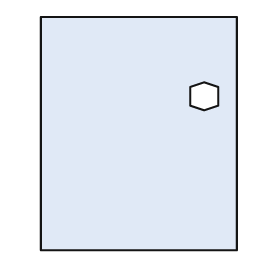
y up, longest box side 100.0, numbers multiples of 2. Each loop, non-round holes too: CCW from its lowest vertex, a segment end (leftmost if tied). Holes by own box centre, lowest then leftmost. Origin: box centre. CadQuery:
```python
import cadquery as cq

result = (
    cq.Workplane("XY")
    .moveTo(-42.0, -50.0)
    .lineTo(42.0, -50.0)
    .lineTo(42.0, 50.0)
    .lineTo(-42.0, 50.0)
    .close()
    .moveTo(28.0, 10.0)
    .lineTo(34.0, 12.0)
    .lineTo(34.0, 20.0)
    .lineTo(28.0, 22.0)
    .lineTo(22.0, 20.0)
    .lineTo(22.0, 12.0)
    .close()
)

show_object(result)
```